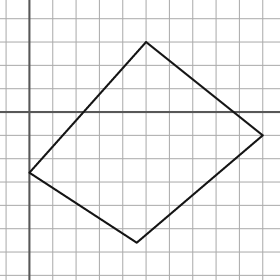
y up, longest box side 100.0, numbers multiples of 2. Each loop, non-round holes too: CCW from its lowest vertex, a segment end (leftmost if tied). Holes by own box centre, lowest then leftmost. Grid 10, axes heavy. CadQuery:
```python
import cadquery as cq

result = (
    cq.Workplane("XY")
    .moveTo(46.0, -56.0)
    .lineTo(100.0, -10.0)
    .lineTo(50.0, 30.0)
    .lineTo(0.0, -26.0)
    .close()
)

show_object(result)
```